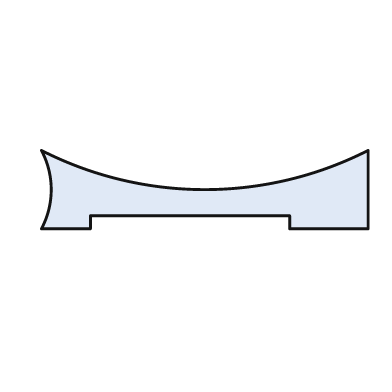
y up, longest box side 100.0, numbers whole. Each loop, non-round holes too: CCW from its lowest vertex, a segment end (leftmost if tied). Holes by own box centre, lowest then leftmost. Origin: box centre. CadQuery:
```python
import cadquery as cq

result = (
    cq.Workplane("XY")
    .moveTo(-50.0, -12.0)
    .lineTo(-35.0, -12.0)
    .lineTo(-35.0, -8.0)
    .lineTo(26.0, -8.0)
    .lineTo(26.0, -12.0)
    .lineTo(50.0, -12.0)
    .lineTo(50.0, 12.0)
    .threePointArc((0.0, 0.0), (-50.0, 12.0))
    .threePointArc((-47.0, 0.0), (-50.0, -12.0))
    .close()
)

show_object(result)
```